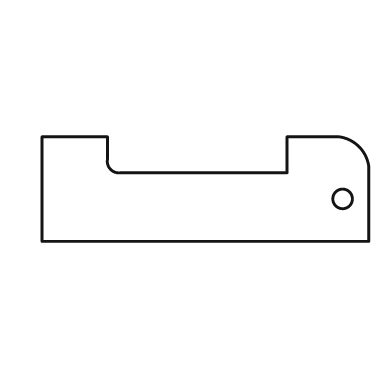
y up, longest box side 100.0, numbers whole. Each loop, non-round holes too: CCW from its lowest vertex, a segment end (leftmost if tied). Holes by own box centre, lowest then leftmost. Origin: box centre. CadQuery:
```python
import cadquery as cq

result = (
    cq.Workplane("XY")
    .moveTo(-50.0, -16.0)
    .lineTo(50.0, -16.0)
    .lineTo(50.0, 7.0)
    .threePointArc((47.0, 13.0), (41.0, 16.0))
    .lineTo(25.0, 16.0)
    .lineTo(25.0, 5.0)
    .lineTo(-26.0, 5.0)
    .threePointArc((-29.0, 6.0), (-30.0, 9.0))
    .lineTo(-30.0, 16.0)
    .lineTo(-50.0, 16.0)
    .close()
    .moveTo(42.0, -3.0)
    .circle(3.0)
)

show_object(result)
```